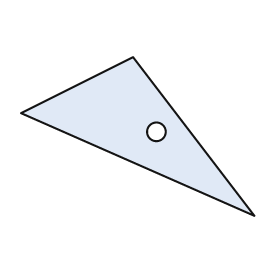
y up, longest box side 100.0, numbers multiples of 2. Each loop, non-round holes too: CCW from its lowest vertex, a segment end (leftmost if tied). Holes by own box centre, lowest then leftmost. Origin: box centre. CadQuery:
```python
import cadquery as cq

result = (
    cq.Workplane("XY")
    .moveTo(50.0, -34.0)
    .lineTo(-2.0, 34.0)
    .lineTo(-50.0, 10.0)
    .close()
    .moveTo(8.0, 2.0)
    .circle(4.0)
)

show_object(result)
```